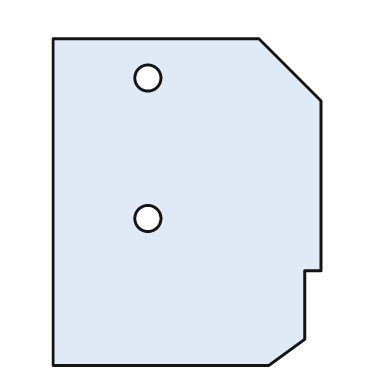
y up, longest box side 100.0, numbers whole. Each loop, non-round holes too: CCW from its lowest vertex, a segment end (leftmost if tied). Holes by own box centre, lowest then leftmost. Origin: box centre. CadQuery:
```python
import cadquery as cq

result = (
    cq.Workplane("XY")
    .moveTo(-41.0, -50.0)
    .lineTo(25.0, -50.0)
    .lineTo(36.0, -42.0)
    .lineTo(36.0, -21.0)
    .lineTo(41.0, -21.0)
    .lineTo(41.0, 31.0)
    .lineTo(22.0, 50.0)
    .lineTo(-41.0, 50.0)
    .close()
    .moveTo(-12.0, -5.0)
    .circle(4.0)
    .moveTo(-12.0, 38.0)
    .circle(4.0)
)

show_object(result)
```